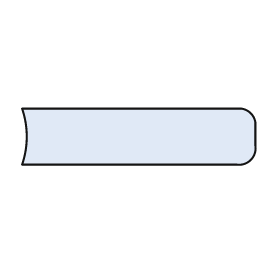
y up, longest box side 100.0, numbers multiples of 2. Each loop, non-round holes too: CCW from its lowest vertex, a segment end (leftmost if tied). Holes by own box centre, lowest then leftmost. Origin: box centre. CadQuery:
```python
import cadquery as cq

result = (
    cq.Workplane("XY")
    .moveTo(-50.0, -12.0)
    .lineTo(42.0, -12.0)
    .threePointArc((48.0, -10.0), (50.0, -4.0))
    .lineTo(50.0, 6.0)
    .threePointArc((48.0, 10.0), (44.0, 12.0))
    .lineTo(-50.0, 12.0)
    .threePointArc((-48.0, 0.0), (-50.0, -12.0))
    .close()
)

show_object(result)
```